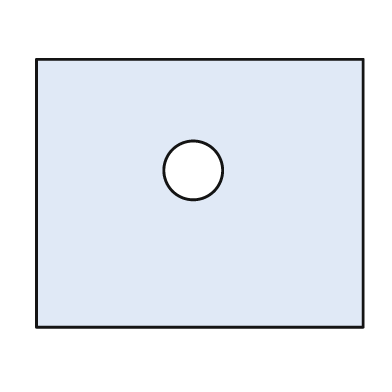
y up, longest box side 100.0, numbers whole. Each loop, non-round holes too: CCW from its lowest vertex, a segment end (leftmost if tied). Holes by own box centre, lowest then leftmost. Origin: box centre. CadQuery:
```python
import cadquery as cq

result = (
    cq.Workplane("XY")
    .moveTo(-50.0, -41.0)
    .lineTo(50.0, -41.0)
    .lineTo(50.0, 41.0)
    .lineTo(-50.0, 41.0)
    .close()
    .moveTo(-2.0, 7.0)
    .circle(9.0)
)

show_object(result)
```